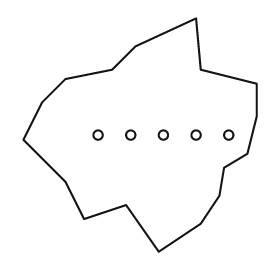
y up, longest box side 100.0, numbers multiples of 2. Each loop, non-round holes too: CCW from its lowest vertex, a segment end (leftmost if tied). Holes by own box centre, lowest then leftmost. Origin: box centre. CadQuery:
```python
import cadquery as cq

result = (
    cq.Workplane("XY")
    .moveTo(8.0, -50.0)
    .lineTo(26.0, -38.0)
    .lineTo(34.0, -26.0)
    .lineTo(36.0, -14.0)
    .lineTo(46.0, -8.0)
    .lineTo(50.0, 8.0)
    .lineTo(50.0, 22.0)
    .lineTo(26.0, 28.0)
    .lineTo(24.0, 50.0)
    .lineTo(-2.0, 38.0)
    .lineTo(-12.0, 28.0)
    .lineTo(-32.0, 24.0)
    .lineTo(-42.0, 14.0)
    .lineTo(-50.0, -2.0)
    .lineTo(-32.0, -20.0)
    .lineTo(-24.0, -36.0)
    .lineTo(-6.0, -30.0)
    .close()
    .moveTo(-18.0, 0.0)
    .circle(2.0)
    .moveTo(-4.0, 0.0)
    .circle(2.0)
    .moveTo(10.0, 0.0)
    .circle(2.0)
    .moveTo(24.0, 0.0)
    .circle(2.0)
    .moveTo(38.0, 0.0)
    .circle(2.0)
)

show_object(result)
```